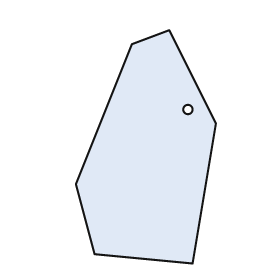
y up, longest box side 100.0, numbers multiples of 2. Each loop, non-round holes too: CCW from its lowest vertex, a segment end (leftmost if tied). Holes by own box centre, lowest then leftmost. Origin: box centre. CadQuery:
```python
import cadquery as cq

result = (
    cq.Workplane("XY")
    .moveTo(20.0, -50.0)
    .lineTo(30.0, 10.0)
    .lineTo(10.0, 50.0)
    .lineTo(-6.0, 44.0)
    .lineTo(-30.0, -16.0)
    .lineTo(-22.0, -46.0)
    .close()
    .moveTo(18.0, 16.0)
    .circle(2.0)
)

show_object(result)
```